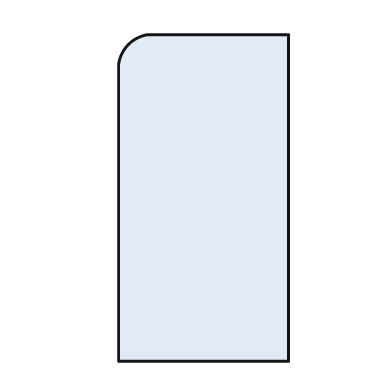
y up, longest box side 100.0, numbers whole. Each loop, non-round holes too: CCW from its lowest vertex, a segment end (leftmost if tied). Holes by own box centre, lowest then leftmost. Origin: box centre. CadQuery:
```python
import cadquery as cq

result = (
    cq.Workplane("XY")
    .moveTo(-26.0, -50.0)
    .lineTo(26.0, -50.0)
    .lineTo(26.0, 50.0)
    .lineTo(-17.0, 50.0)
    .threePointArc((-23.0, 47.0), (-26.0, 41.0))
    .close()
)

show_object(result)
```